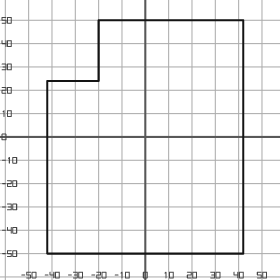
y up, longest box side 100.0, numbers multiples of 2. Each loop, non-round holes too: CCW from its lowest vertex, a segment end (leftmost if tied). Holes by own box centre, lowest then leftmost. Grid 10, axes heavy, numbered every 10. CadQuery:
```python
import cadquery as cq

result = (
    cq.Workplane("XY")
    .moveTo(-42.0, -50.0)
    .lineTo(42.0, -50.0)
    .lineTo(42.0, 50.0)
    .lineTo(-20.0, 50.0)
    .lineTo(-20.0, 24.0)
    .lineTo(-42.0, 24.0)
    .close()
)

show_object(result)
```